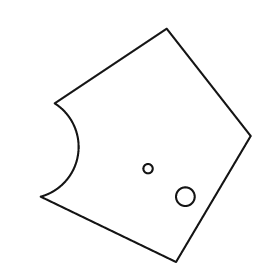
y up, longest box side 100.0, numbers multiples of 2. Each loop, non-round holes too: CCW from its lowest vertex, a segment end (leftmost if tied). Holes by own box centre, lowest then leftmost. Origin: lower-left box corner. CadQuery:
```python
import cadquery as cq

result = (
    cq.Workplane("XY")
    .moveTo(58.0, 0.0)
    .lineTo(90.0, 54.0)
    .lineTo(54.0, 100.0)
    .lineTo(6.0, 68.0)
    .threePointArc((16.0, 46.0), (0.0, 28.0))
    .close()
    .moveTo(62.0, 28.0)
    .circle(4.0)
    .moveTo(46.0, 40.0)
    .circle(2.0)
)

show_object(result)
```